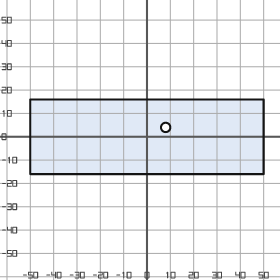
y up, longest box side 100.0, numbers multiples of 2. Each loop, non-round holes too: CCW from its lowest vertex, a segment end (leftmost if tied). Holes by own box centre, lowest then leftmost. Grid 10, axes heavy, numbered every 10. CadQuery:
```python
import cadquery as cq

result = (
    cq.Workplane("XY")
    .moveTo(-50.0, -16.0)
    .lineTo(50.0, -16.0)
    .lineTo(50.0, 16.0)
    .lineTo(-50.0, 16.0)
    .close()
    .moveTo(8.0, 4.0)
    .circle(2.0)
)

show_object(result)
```